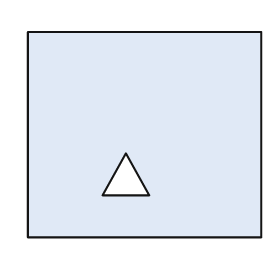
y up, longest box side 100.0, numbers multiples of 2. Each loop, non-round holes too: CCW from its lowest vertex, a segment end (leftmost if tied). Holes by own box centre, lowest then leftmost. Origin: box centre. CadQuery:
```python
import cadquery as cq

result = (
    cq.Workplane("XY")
    .moveTo(-50.0, -44.0)
    .lineTo(50.0, -44.0)
    .lineTo(50.0, 44.0)
    .lineTo(-50.0, 44.0)
    .close()
    .moveTo(-18.0, -26.0)
    .lineTo(2.0, -26.0)
    .lineTo(-8.0, -8.0)
    .close()
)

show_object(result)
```